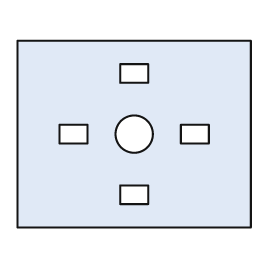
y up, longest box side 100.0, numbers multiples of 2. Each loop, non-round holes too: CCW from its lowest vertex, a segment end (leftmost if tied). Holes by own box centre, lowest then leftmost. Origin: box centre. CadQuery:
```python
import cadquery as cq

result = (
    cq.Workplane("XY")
    .moveTo(-50.0, -40.0)
    .lineTo(50.0, -40.0)
    .lineTo(50.0, 40.0)
    .lineTo(-50.0, 40.0)
    .close()
    .moveTo(-6.0, -30.0)
    .lineTo(6.0, -30.0)
    .lineTo(6.0, -22.0)
    .lineTo(-6.0, -22.0)
    .close()
    .moveTo(-32.0, -4.0)
    .lineTo(-20.0, -4.0)
    .lineTo(-20.0, 4.0)
    .lineTo(-32.0, 4.0)
    .close()
    .moveTo(0.0, 0.0)
    .circle(8.0)
    .moveTo(20.0, -4.0)
    .lineTo(32.0, -4.0)
    .lineTo(32.0, 4.0)
    .lineTo(20.0, 4.0)
    .close()
    .moveTo(-6.0, 22.0)
    .lineTo(6.0, 22.0)
    .lineTo(6.0, 30.0)
    .lineTo(-6.0, 30.0)
    .close()
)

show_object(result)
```